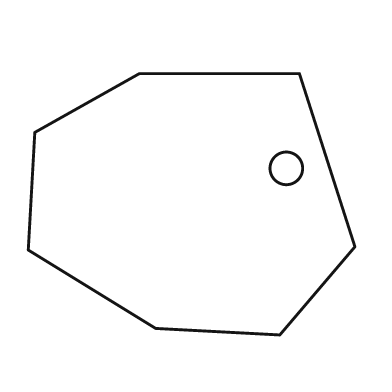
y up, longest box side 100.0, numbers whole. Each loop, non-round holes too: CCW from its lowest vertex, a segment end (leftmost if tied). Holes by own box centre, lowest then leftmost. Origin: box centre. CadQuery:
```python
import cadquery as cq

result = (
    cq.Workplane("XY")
    .moveTo(27.0, -40.0)
    .lineTo(50.0, -13.0)
    .lineTo(33.0, 40.0)
    .lineTo(-16.0, 40.0)
    .lineTo(-48.0, 22.0)
    .lineTo(-50.0, -14.0)
    .lineTo(-11.0, -38.0)
    .close()
    .moveTo(29.0, 11.0)
    .circle(5.0)
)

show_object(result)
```